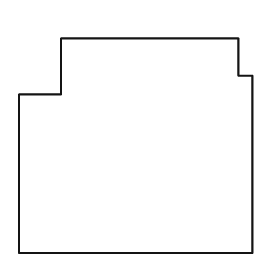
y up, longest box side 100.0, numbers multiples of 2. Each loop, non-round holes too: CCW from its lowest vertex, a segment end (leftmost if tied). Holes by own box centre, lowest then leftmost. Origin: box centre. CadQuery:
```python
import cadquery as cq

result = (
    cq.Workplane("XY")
    .moveTo(-50.0, -46.0)
    .lineTo(50.0, -46.0)
    .lineTo(50.0, 30.0)
    .lineTo(44.0, 30.0)
    .lineTo(44.0, 46.0)
    .lineTo(-32.0, 46.0)
    .lineTo(-32.0, 22.0)
    .lineTo(-50.0, 22.0)
    .close()
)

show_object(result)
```